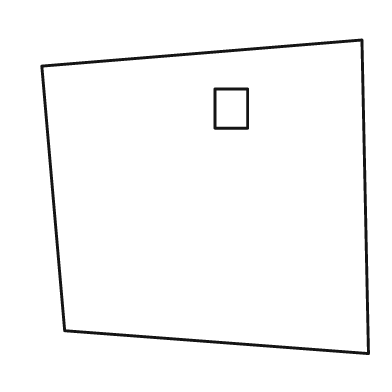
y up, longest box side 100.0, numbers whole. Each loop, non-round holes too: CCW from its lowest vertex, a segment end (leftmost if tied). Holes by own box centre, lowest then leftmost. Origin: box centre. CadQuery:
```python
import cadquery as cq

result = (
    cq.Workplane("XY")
    .moveTo(50.0, -48.0)
    .lineTo(48.0, 48.0)
    .lineTo(-50.0, 40.0)
    .lineTo(-43.0, -41.0)
    .close()
    .moveTo(3.0, 21.0)
    .lineTo(13.0, 21.0)
    .lineTo(13.0, 33.0)
    .lineTo(3.0, 33.0)
    .close()
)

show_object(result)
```